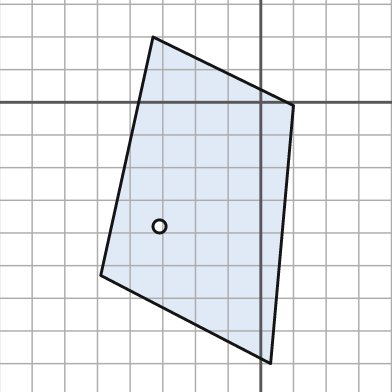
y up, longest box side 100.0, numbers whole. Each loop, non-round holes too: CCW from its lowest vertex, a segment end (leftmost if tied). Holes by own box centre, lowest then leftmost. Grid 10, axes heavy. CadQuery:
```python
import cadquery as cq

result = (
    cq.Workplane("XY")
    .moveTo(3.0, -80.0)
    .lineTo(10.0, -1.0)
    .lineTo(-33.0, 20.0)
    .lineTo(-49.0, -53.0)
    .close()
    .moveTo(-31.0, -38.0)
    .circle(2.0)
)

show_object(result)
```